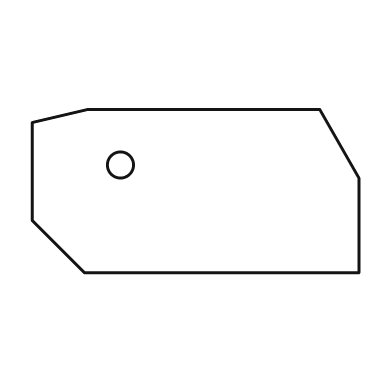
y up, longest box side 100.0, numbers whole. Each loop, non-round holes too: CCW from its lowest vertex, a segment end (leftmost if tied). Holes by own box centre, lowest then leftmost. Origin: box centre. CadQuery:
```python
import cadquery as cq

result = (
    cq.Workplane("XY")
    .moveTo(-34.0, -25.0)
    .lineTo(50.0, -25.0)
    .lineTo(50.0, 4.0)
    .lineTo(38.0, 25.0)
    .lineTo(-33.0, 25.0)
    .lineTo(-50.0, 21.0)
    .lineTo(-50.0, -9.0)
    .close()
    .moveTo(-23.0, 8.0)
    .circle(4.0)
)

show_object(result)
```